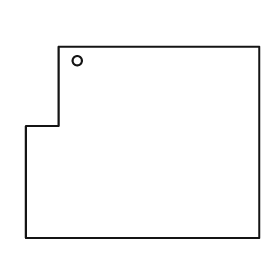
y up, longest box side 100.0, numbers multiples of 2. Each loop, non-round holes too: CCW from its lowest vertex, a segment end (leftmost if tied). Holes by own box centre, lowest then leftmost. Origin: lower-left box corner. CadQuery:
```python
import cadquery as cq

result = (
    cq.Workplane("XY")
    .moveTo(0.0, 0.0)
    .lineTo(100.0, 0.0)
    .lineTo(100.0, 82.0)
    .lineTo(14.0, 82.0)
    .lineTo(14.0, 48.0)
    .lineTo(0.0, 48.0)
    .close()
    .moveTo(22.0, 76.0)
    .circle(2.0)
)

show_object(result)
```